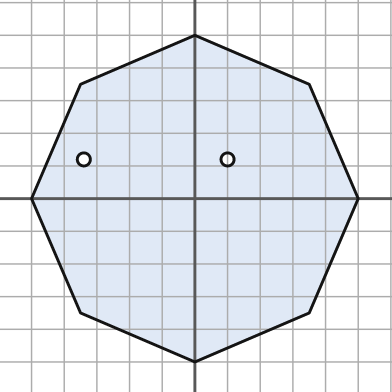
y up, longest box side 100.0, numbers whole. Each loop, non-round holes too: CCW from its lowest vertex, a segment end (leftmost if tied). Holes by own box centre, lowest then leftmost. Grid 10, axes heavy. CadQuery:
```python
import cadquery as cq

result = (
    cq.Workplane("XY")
    .moveTo(0.0, -50.0)
    .lineTo(35.0, -35.0)
    .lineTo(50.0, 0.0)
    .lineTo(35.0, 35.0)
    .lineTo(0.0, 50.0)
    .lineTo(-35.0, 35.0)
    .lineTo(-50.0, 0.0)
    .lineTo(-35.0, -35.0)
    .close()
    .moveTo(-34.0, 12.0)
    .circle(2.0)
    .moveTo(10.0, 12.0)
    .circle(2.0)
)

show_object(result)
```